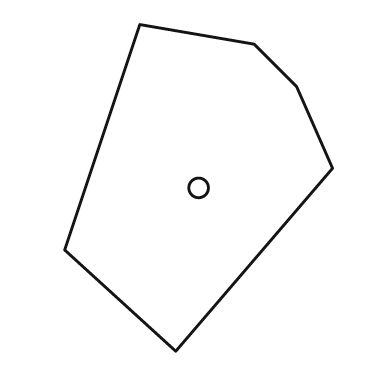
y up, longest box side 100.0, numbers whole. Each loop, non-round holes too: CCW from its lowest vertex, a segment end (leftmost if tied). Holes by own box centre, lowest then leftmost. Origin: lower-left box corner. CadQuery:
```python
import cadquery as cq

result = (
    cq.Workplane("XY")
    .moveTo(34.0, 0.0)
    .lineTo(82.0, 56.0)
    .lineTo(71.0, 81.0)
    .lineTo(58.0, 94.0)
    .lineTo(23.0, 100.0)
    .lineTo(0.0, 31.0)
    .close()
    .moveTo(41.0, 50.0)
    .circle(3.0)
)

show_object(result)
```